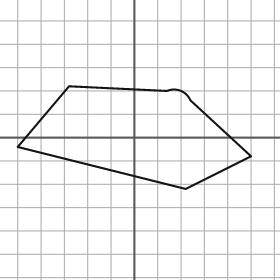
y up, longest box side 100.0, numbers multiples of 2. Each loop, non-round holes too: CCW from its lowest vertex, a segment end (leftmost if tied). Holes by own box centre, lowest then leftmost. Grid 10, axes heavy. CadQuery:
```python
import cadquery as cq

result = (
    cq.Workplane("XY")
    .moveTo(22.0, -22.0)
    .lineTo(50.0, -8.0)
    .lineTo(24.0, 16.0)
    .threePointArc((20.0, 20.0), (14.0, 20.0))
    .lineTo(-28.0, 22.0)
    .lineTo(-50.0, -4.0)
    .close()
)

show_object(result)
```